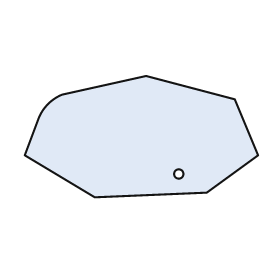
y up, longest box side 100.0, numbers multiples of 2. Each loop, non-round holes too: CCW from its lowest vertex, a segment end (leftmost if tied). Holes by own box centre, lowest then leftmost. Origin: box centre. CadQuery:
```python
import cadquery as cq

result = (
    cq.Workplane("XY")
    .moveTo(-20.0, -26.0)
    .lineTo(28.0, -24.0)
    .lineTo(50.0, -8.0)
    .lineTo(40.0, 16.0)
    .lineTo(2.0, 26.0)
    .lineTo(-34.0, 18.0)
    .threePointArc((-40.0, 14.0), (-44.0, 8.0))
    .lineTo(-50.0, -8.0)
    .close()
    .moveTo(16.0, -16.0)
    .circle(2.0)
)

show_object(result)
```